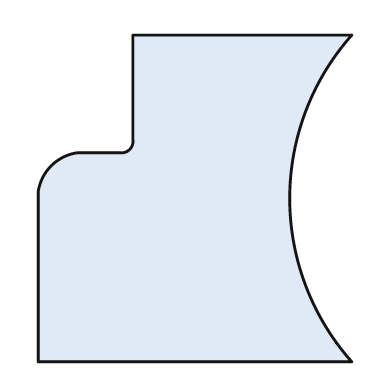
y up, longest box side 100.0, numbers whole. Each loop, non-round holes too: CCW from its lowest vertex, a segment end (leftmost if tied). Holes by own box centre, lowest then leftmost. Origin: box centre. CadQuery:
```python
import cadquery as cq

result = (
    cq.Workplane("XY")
    .moveTo(-48.0, -50.0)
    .lineTo(48.0, -50.0)
    .threePointArc((29.0, 0.0), (48.0, 50.0))
    .lineTo(-19.0, 50.0)
    .lineTo(-19.0, 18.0)
    .threePointArc((-20.0, 15.0), (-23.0, 14.0))
    .lineTo(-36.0, 14.0)
    .threePointArc((-44.0, 10.0), (-48.0, 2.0))
    .close()
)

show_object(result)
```